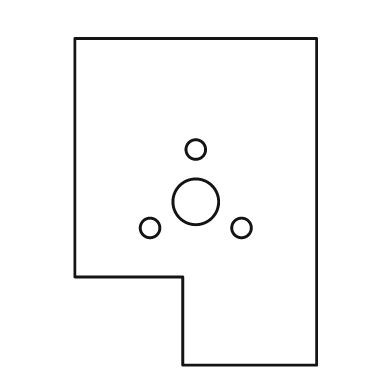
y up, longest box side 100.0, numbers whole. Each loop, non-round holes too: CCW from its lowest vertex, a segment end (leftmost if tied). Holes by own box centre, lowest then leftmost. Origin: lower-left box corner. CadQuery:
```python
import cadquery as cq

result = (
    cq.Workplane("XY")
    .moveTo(33.0, 0.0)
    .lineTo(74.0, 0.0)
    .lineTo(74.0, 100.0)
    .lineTo(0.0, 100.0)
    .lineTo(0.0, 27.0)
    .lineTo(33.0, 27.0)
    .close()
    .moveTo(23.0, 42.0)
    .circle(3.0)
    .moveTo(51.0, 42.0)
    .circle(3.0)
    .moveTo(37.0, 50.0)
    .circle(7.0)
    .moveTo(37.0, 66.0)
    .circle(3.0)
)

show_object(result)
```